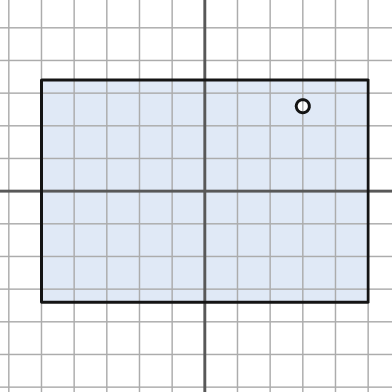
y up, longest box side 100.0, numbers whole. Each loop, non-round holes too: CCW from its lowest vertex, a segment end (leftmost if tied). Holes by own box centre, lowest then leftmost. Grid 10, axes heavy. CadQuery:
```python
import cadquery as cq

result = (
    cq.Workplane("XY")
    .moveTo(-50.0, -34.0)
    .lineTo(50.0, -34.0)
    .lineTo(50.0, 34.0)
    .lineTo(-50.0, 34.0)
    .close()
    .moveTo(30.0, 26.0)
    .circle(2.0)
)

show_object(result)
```